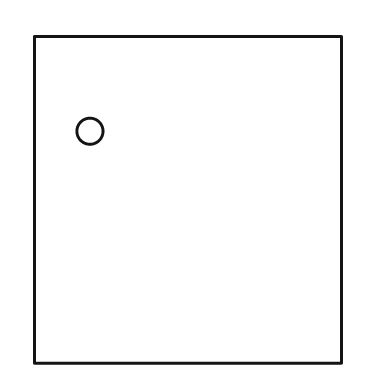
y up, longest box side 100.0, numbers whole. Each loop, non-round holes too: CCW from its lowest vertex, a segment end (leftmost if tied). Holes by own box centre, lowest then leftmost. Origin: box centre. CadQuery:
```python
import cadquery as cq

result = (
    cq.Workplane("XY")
    .moveTo(-47.0, -50.0)
    .lineTo(47.0, -50.0)
    .lineTo(47.0, 50.0)
    .lineTo(-47.0, 50.0)
    .close()
    .moveTo(-30.0, 21.0)
    .circle(4.0)
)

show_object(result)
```